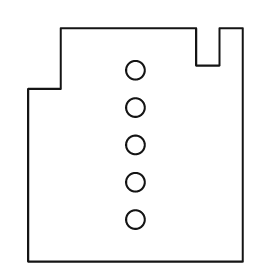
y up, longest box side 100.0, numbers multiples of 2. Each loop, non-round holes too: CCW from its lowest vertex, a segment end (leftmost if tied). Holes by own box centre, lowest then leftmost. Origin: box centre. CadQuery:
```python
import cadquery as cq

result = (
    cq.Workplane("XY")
    .moveTo(-46.0, -50.0)
    .lineTo(46.0, -50.0)
    .lineTo(46.0, 50.0)
    .lineTo(36.0, 50.0)
    .lineTo(36.0, 34.0)
    .lineTo(26.0, 34.0)
    .lineTo(26.0, 50.0)
    .lineTo(-32.0, 50.0)
    .lineTo(-32.0, 24.0)
    .lineTo(-46.0, 24.0)
    .close()
    .moveTo(0.0, -32.0)
    .circle(4.0)
    .moveTo(0.0, -16.0)
    .circle(4.0)
    .moveTo(0.0, 0.0)
    .circle(4.0)
    .moveTo(0.0, 16.0)
    .circle(4.0)
    .moveTo(0.0, 32.0)
    .circle(4.0)
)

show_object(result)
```